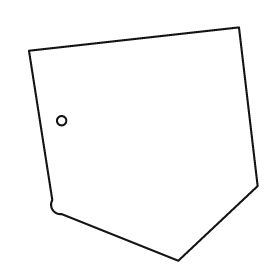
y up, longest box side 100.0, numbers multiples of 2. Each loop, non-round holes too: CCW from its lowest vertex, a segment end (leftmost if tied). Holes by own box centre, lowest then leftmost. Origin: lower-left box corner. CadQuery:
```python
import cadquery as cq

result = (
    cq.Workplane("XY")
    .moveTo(64.0, 0.0)
    .lineTo(98.0, 32.0)
    .lineTo(90.0, 100.0)
    .lineTo(0.0, 90.0)
    .lineTo(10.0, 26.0)
    .threePointArc((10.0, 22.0), (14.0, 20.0))
    .close()
    .moveTo(14.0, 60.0)
    .circle(2.0)
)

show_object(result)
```